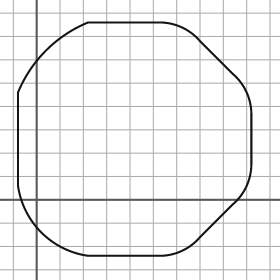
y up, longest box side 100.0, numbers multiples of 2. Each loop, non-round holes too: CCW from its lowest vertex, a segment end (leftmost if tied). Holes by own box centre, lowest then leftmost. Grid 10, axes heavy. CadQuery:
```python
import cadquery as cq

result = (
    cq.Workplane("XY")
    .moveTo(22.0, -24.0)
    .lineTo(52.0, -24.0)
    .threePointArc((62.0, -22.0), (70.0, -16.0))
    .lineTo(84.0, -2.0)
    .threePointArc((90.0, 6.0), (92.0, 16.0))
    .lineTo(92.0, 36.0)
    .threePointArc((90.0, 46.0), (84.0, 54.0))
    .lineTo(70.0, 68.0)
    .threePointArc((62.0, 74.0), (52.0, 76.0))
    .lineTo(22.0, 76.0)
    .threePointArc((4.0, 64.0), (-8.0, 46.0))
    .lineTo(-8.0, 6.0)
    .threePointArc((2.0, -14.0), (22.0, -24.0))
    .close()
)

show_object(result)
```